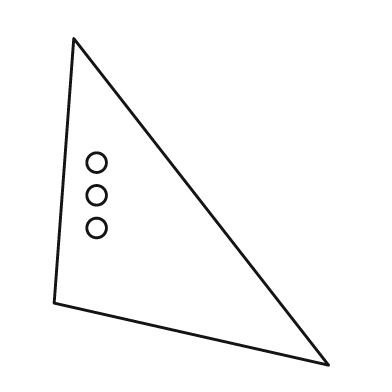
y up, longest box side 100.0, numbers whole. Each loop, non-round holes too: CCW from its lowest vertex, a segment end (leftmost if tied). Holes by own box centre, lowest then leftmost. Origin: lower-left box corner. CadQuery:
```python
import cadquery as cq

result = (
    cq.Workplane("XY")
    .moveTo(84.0, 0.0)
    .lineTo(6.0, 100.0)
    .lineTo(0.0, 19.0)
    .close()
    .moveTo(13.0, 42.0)
    .circle(3.0)
    .moveTo(13.0, 52.0)
    .circle(3.0)
    .moveTo(13.0, 62.0)
    .circle(3.0)
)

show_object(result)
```